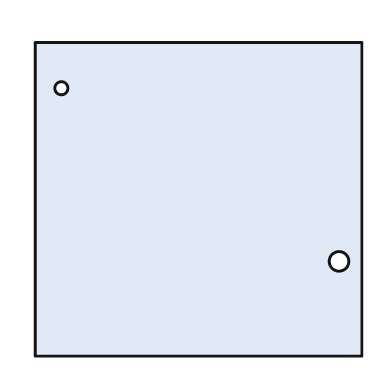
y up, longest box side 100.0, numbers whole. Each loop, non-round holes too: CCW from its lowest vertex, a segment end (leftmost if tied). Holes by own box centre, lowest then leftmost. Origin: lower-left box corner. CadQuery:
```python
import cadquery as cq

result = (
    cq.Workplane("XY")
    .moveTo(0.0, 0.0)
    .lineTo(100.0, 0.0)
    .lineTo(100.0, 96.0)
    .lineTo(0.0, 96.0)
    .close()
    .moveTo(93.0, 29.0)
    .circle(3.0)
    .moveTo(8.0, 82.0)
    .circle(2.0)
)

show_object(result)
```